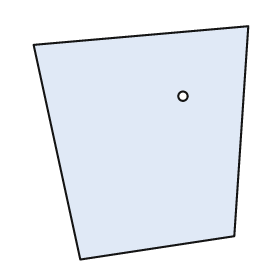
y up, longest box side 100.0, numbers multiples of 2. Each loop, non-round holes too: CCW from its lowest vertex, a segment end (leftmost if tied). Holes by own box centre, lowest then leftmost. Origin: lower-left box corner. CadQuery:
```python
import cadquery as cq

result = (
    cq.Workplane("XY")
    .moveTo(20.0, 0.0)
    .lineTo(86.0, 10.0)
    .lineTo(92.0, 100.0)
    .lineTo(0.0, 92.0)
    .close()
    .moveTo(64.0, 70.0)
    .circle(2.0)
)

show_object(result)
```